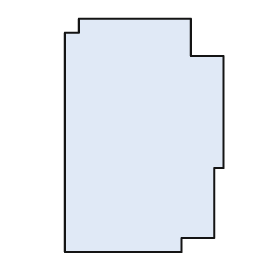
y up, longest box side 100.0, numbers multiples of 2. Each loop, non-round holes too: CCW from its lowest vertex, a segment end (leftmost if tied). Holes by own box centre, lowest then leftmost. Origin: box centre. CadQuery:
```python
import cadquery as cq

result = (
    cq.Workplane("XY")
    .moveTo(-34.0, -50.0)
    .lineTo(16.0, -50.0)
    .lineTo(16.0, -44.0)
    .lineTo(30.0, -44.0)
    .lineTo(30.0, -14.0)
    .lineTo(34.0, -14.0)
    .lineTo(34.0, 34.0)
    .lineTo(20.0, 34.0)
    .lineTo(20.0, 50.0)
    .lineTo(-28.0, 50.0)
    .lineTo(-28.0, 44.0)
    .lineTo(-34.0, 44.0)
    .close()
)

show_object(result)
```